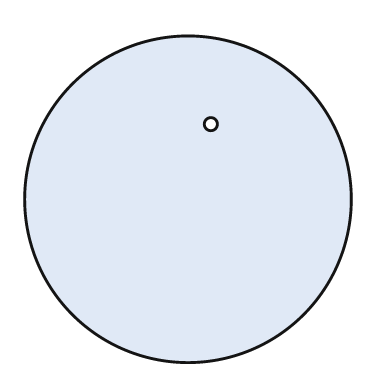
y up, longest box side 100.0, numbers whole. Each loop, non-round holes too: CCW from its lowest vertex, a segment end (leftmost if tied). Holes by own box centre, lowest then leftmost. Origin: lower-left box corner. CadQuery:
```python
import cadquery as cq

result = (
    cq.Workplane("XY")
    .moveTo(50.0, 50.0)
    .circle(50.0)
    .moveTo(57.0, 73.0)
    .circle(2.0)
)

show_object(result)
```